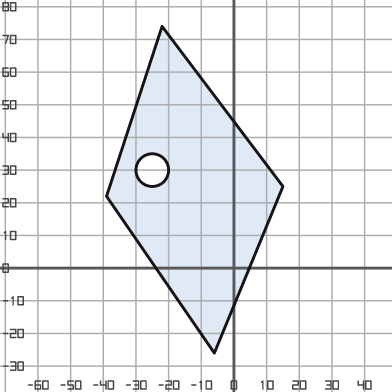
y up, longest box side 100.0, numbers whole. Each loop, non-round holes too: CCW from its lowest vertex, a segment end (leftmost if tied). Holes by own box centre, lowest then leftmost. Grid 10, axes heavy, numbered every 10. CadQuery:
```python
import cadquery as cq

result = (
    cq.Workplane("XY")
    .moveTo(-6.0, -26.0)
    .lineTo(15.0, 25.0)
    .lineTo(-22.0, 74.0)
    .lineTo(-39.0, 22.0)
    .close()
    .moveTo(-25.0, 30.0)
    .circle(5.0)
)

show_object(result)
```